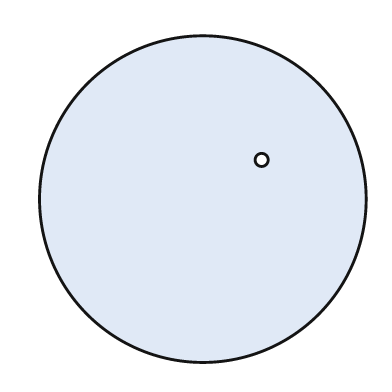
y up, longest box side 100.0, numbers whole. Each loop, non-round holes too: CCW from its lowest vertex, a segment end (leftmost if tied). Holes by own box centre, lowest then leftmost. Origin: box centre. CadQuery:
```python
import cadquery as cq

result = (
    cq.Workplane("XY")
    .moveTo(0.0, 0.0)
    .circle(50.0)
    .moveTo(18.0, 12.0)
    .circle(2.0)
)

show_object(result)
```